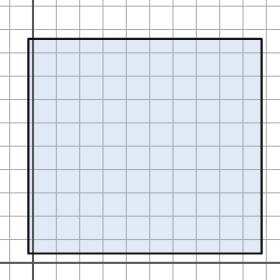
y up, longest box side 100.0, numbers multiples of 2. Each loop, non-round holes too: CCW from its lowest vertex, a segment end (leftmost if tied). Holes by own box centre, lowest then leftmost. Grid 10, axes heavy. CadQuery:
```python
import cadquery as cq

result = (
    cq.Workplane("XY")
    .moveTo(-2.0, 4.0)
    .lineTo(98.0, 4.0)
    .lineTo(98.0, 96.0)
    .lineTo(-2.0, 96.0)
    .close()
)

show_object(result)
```